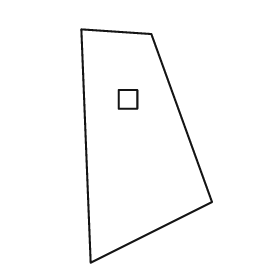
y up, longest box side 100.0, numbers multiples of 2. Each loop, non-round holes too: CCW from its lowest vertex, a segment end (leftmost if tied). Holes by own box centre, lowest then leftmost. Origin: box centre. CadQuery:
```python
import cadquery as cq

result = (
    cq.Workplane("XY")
    .moveTo(-24.0, -50.0)
    .lineTo(28.0, -24.0)
    .lineTo(2.0, 48.0)
    .lineTo(-28.0, 50.0)
    .close()
    .moveTo(-12.0, 16.0)
    .lineTo(-4.0, 16.0)
    .lineTo(-4.0, 24.0)
    .lineTo(-12.0, 24.0)
    .close()
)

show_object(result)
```